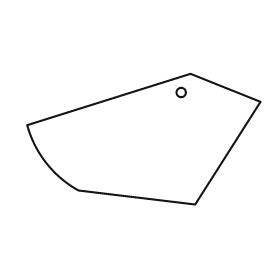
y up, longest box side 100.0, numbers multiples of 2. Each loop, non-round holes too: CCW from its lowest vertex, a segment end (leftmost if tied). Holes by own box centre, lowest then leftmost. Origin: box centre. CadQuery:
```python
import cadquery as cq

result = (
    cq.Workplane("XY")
    .moveTo(22.0, -28.0)
    .lineTo(50.0, 16.0)
    .lineTo(20.0, 28.0)
    .lineTo(-50.0, 6.0)
    .threePointArc((-42.0, -10.0), (-28.0, -22.0))
    .close()
    .moveTo(16.0, 20.0)
    .circle(2.0)
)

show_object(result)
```